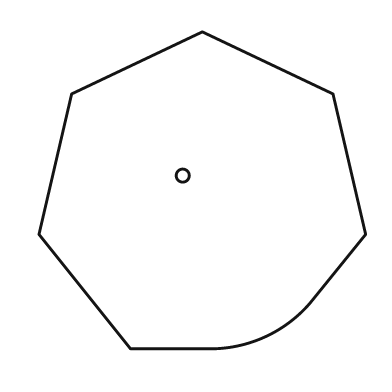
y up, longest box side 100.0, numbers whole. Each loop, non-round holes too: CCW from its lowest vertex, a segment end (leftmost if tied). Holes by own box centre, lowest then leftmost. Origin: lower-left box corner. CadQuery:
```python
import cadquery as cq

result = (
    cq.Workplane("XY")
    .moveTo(28.0, 0.0)
    .lineTo(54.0, 0.0)
    .threePointArc((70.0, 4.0), (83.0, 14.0))
    .lineTo(100.0, 35.0)
    .lineTo(90.0, 78.0)
    .lineTo(50.0, 97.0)
    .lineTo(10.0, 78.0)
    .lineTo(0.0, 35.0)
    .close()
    .moveTo(44.0, 53.0)
    .circle(2.0)
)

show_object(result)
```